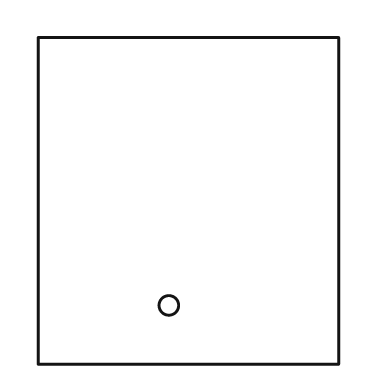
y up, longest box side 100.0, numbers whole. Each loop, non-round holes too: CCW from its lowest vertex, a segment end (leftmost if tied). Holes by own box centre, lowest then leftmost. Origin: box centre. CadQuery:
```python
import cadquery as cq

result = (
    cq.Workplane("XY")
    .moveTo(-46.0, -50.0)
    .lineTo(46.0, -50.0)
    .lineTo(46.0, 50.0)
    .lineTo(-46.0, 50.0)
    .close()
    .moveTo(-6.0, -32.0)
    .circle(3.0)
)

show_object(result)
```